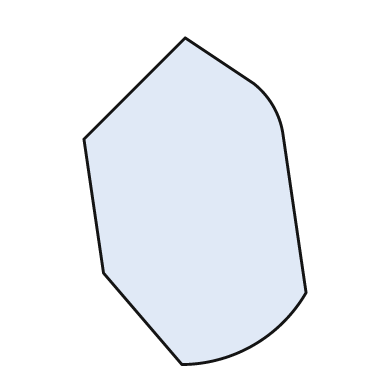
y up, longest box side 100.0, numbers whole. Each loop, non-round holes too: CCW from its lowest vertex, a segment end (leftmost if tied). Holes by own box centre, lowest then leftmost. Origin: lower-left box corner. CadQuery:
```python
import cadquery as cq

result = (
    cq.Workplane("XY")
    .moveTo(30.0, 0.0)
    .threePointArc((52.0, 6.0), (68.0, 22.0))
    .lineTo(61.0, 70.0)
    .threePointArc((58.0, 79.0), (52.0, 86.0))
    .lineTo(31.0, 100.0)
    .lineTo(0.0, 69.0)
    .lineTo(6.0, 28.0)
    .close()
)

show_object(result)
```